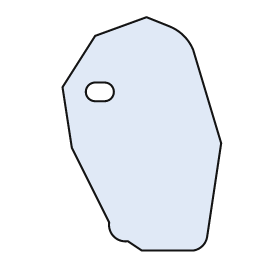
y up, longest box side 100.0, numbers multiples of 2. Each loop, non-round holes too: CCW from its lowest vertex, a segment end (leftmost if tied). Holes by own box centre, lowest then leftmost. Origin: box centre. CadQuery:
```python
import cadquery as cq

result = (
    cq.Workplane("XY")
    .moveTo(0.0, -50.0)
    .lineTo(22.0, -50.0)
    .threePointArc((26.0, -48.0), (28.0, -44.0))
    .lineTo(34.0, -4.0)
    .lineTo(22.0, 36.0)
    .threePointArc((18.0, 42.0), (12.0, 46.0))
    .lineTo(2.0, 50.0)
    .lineTo(-20.0, 42.0)
    .lineTo(-34.0, 20.0)
    .lineTo(-30.0, -6.0)
    .lineTo(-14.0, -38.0)
    .threePointArc((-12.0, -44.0), (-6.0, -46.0))
    .close()
    .moveTo(-20.0, 14.0)
    .lineTo(-16.0, 14.0)
    .threePointArc((-12.0, 18.0), (-16.0, 22.0))
    .lineTo(-20.0, 22.0)
    .threePointArc((-24.0, 18.0), (-20.0, 14.0))
    .close()
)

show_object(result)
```